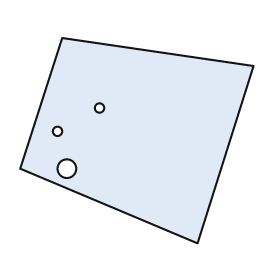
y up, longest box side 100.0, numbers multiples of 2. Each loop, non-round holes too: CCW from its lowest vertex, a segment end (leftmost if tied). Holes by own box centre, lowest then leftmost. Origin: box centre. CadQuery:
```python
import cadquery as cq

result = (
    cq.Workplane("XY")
    .moveTo(26.0, -44.0)
    .lineTo(50.0, 32.0)
    .lineTo(-32.0, 44.0)
    .lineTo(-50.0, -12.0)
    .close()
    .moveTo(-30.0, -12.0)
    .circle(4.0)
    .moveTo(-34.0, 4.0)
    .circle(2.0)
    .moveTo(-16.0, 14.0)
    .circle(2.0)
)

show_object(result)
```